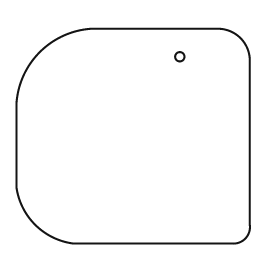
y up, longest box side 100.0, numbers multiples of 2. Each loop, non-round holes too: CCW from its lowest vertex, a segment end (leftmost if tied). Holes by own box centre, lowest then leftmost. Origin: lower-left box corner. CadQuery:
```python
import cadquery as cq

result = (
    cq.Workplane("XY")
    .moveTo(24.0, 0.0)
    .lineTo(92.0, 0.0)
    .threePointArc((98.0, 2.0), (100.0, 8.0))
    .lineTo(100.0, 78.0)
    .threePointArc((96.0, 88.0), (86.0, 92.0))
    .lineTo(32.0, 92.0)
    .threePointArc((10.0, 82.0), (0.0, 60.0))
    .lineTo(0.0, 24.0)
    .threePointArc((8.0, 8.0), (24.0, 0.0))
    .close()
    .moveTo(70.0, 80.0)
    .circle(2.0)
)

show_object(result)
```